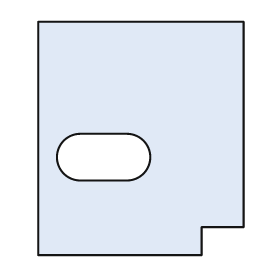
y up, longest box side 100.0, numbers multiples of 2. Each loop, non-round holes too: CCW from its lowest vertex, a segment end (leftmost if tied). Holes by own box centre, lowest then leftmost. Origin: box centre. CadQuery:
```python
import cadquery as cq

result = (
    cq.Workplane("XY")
    .moveTo(-44.0, -50.0)
    .lineTo(26.0, -50.0)
    .lineTo(26.0, -38.0)
    .lineTo(44.0, -38.0)
    .lineTo(44.0, 50.0)
    .lineTo(-44.0, 50.0)
    .close()
    .moveTo(-26.0, -18.0)
    .lineTo(-6.0, -18.0)
    .threePointArc((4.0, -8.0), (-6.0, 2.0))
    .lineTo(-26.0, 2.0)
    .threePointArc((-36.0, -8.0), (-26.0, -18.0))
    .close()
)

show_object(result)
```